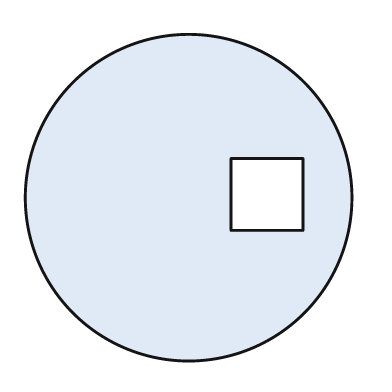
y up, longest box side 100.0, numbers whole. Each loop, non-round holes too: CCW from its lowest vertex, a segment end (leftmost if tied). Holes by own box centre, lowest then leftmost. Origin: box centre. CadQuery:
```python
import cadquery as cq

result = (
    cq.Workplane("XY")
    .moveTo(0.0, 0.0)
    .circle(50.0)
    .moveTo(13.0, -10.0)
    .lineTo(35.0, -10.0)
    .lineTo(35.0, 12.0)
    .lineTo(13.0, 12.0)
    .close()
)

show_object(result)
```